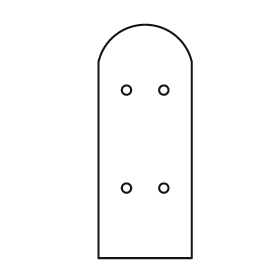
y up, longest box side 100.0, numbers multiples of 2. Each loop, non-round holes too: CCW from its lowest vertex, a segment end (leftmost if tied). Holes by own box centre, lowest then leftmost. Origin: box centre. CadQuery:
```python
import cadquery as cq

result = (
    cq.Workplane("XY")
    .moveTo(-20.0, -50.0)
    .lineTo(20.0, -50.0)
    .lineTo(20.0, 34.0)
    .threePointArc((0.0, 50.0), (-20.0, 34.0))
    .close()
    .moveTo(-8.0, -20.0)
    .circle(2.0)
    .moveTo(8.0, -20.0)
    .circle(2.0)
    .moveTo(-8.0, 22.0)
    .circle(2.0)
    .moveTo(8.0, 22.0)
    .circle(2.0)
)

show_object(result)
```